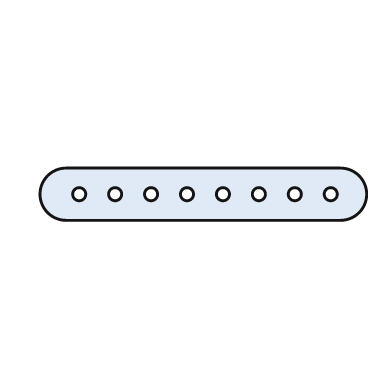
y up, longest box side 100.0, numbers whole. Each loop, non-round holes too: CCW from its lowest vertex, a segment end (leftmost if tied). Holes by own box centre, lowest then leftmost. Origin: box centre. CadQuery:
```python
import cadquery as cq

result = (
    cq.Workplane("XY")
    .moveTo(-42.0, -8.0)
    .lineTo(42.0, -8.0)
    .threePointArc((50.0, 0.0), (42.0, 8.0))
    .lineTo(-42.0, 8.0)
    .threePointArc((-50.0, 0.0), (-42.0, -8.0))
    .close()
    .moveTo(-38.0, 0.0)
    .circle(2.0)
    .moveTo(-27.0, 0.0)
    .circle(2.0)
    .moveTo(-16.0, 0.0)
    .circle(2.0)
    .moveTo(-5.0, 0.0)
    .circle(2.0)
    .moveTo(6.0, 0.0)
    .circle(2.0)
    .moveTo(17.0, 0.0)
    .circle(2.0)
    .moveTo(28.0, 0.0)
    .circle(2.0)
    .moveTo(39.0, 0.0)
    .circle(2.0)
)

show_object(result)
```